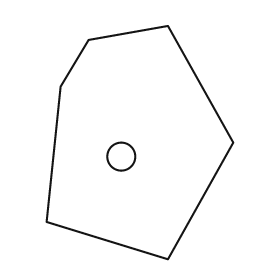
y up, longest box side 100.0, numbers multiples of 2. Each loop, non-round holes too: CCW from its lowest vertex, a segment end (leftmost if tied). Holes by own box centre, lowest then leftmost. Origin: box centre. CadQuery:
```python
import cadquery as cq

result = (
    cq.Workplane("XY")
    .moveTo(12.0, -50.0)
    .lineTo(40.0, 0.0)
    .lineTo(12.0, 50.0)
    .lineTo(-22.0, 44.0)
    .lineTo(-34.0, 24.0)
    .lineTo(-40.0, -34.0)
    .close()
    .moveTo(-8.0, -6.0)
    .circle(6.0)
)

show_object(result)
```